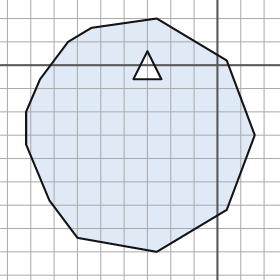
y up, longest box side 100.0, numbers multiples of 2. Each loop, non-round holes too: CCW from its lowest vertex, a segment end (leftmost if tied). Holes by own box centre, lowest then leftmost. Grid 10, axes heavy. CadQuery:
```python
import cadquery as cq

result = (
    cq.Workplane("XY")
    .moveTo(-26.0, -80.0)
    .lineTo(4.0, -62.0)
    .lineTo(16.0, -30.0)
    .lineTo(4.0, 2.0)
    .lineTo(-26.0, 20.0)
    .lineTo(-54.0, 16.0)
    .lineTo(-64.0, 10.0)
    .lineTo(-76.0, -6.0)
    .lineTo(-82.0, -20.0)
    .lineTo(-82.0, -34.0)
    .lineTo(-72.0, -58.0)
    .lineTo(-60.0, -74.0)
    .close()
    .moveTo(-36.0, -6.0)
    .lineTo(-24.0, -6.0)
    .lineTo(-30.0, 6.0)
    .close()
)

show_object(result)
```